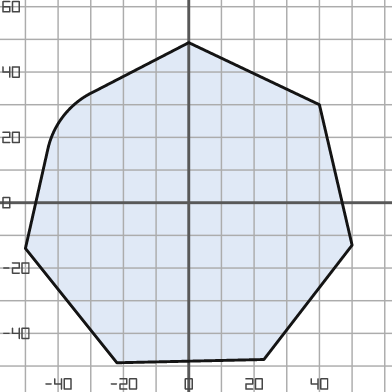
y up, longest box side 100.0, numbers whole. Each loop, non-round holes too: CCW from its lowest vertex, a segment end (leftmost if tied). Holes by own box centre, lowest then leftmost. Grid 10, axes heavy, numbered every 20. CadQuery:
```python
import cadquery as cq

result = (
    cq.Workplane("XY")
    .moveTo(-22.0, -49.0)
    .lineTo(23.0, -48.0)
    .lineTo(50.0, -13.0)
    .lineTo(40.0, 30.0)
    .lineTo(0.0, 49.0)
    .lineTo(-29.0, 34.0)
    .threePointArc((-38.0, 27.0), (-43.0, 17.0))
    .lineTo(-50.0, -14.0)
    .close()
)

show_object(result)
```